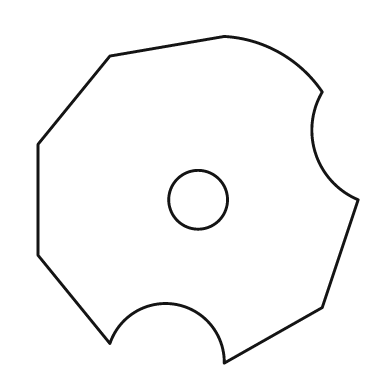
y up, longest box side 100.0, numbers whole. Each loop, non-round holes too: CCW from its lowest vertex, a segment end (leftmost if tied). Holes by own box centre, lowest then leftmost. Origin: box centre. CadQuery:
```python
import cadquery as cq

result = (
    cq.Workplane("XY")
    .moveTo(8.0, -50.0)
    .lineTo(38.0, -33.0)
    .lineTo(49.0, 0.0)
    .threePointArc((36.0, 14.0), (38.0, 33.0))
    .threePointArc((25.0, 45.0), (8.0, 50.0))
    .lineTo(-27.0, 44.0)
    .lineTo(-49.0, 17.0)
    .lineTo(-49.0, -17.0)
    .lineTo(-27.0, -44.0)
    .threePointArc((-7.0, -32.0), (8.0, -50.0))
    .close()
    .moveTo(0.0, 0.0)
    .circle(9.0)
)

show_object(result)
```